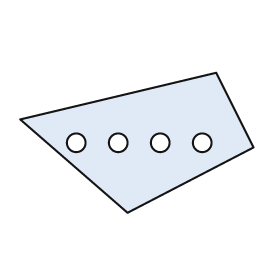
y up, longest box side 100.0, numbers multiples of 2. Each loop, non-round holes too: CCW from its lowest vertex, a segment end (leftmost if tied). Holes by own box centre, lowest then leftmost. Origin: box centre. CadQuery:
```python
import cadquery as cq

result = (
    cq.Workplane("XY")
    .moveTo(-4.0, -30.0)
    .lineTo(50.0, -2.0)
    .lineTo(34.0, 30.0)
    .lineTo(-50.0, 10.0)
    .close()
    .moveTo(-26.0, 0.0)
    .circle(4.0)
    .moveTo(-8.0, 0.0)
    .circle(4.0)
    .moveTo(10.0, 0.0)
    .circle(4.0)
    .moveTo(28.0, 0.0)
    .circle(4.0)
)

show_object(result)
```